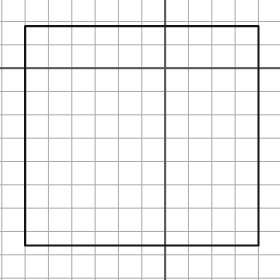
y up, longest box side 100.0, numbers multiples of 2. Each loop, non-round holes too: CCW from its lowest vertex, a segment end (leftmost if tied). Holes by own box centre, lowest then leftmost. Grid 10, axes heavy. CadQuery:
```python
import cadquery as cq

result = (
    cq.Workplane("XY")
    .moveTo(-60.0, -76.0)
    .lineTo(40.0, -76.0)
    .lineTo(40.0, 18.0)
    .lineTo(-60.0, 18.0)
    .close()
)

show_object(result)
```